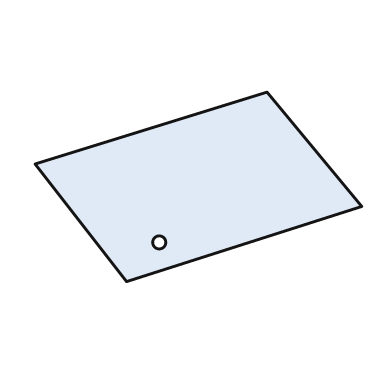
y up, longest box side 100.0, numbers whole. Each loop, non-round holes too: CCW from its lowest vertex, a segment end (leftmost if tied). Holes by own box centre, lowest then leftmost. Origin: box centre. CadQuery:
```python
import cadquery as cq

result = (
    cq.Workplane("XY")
    .moveTo(-22.0, -29.0)
    .lineTo(50.0, -6.0)
    .lineTo(21.0, 29.0)
    .lineTo(-50.0, 7.0)
    .close()
    .moveTo(-12.0, -17.0)
    .circle(2.0)
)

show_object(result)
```